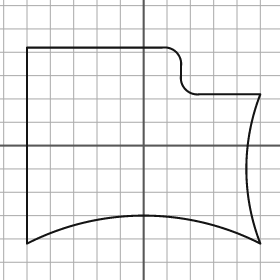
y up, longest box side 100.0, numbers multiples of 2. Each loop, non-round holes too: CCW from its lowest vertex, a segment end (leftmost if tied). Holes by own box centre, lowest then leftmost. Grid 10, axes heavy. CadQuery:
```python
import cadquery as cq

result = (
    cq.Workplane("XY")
    .moveTo(-50.0, -42.0)
    .threePointArc((0.0, -30.0), (50.0, -42.0))
    .threePointArc((44.0, -10.0), (50.0, 22.0))
    .lineTo(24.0, 22.0)
    .threePointArc((18.0, 24.0), (16.0, 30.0))
    .lineTo(16.0, 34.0)
    .threePointArc((14.0, 40.0), (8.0, 42.0))
    .lineTo(-50.0, 42.0)
    .close()
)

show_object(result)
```